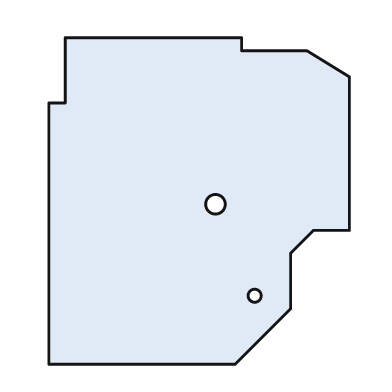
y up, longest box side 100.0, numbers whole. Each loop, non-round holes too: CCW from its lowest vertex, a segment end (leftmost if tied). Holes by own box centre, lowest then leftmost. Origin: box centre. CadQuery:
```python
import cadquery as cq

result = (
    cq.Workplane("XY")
    .moveTo(-46.0, -50.0)
    .lineTo(11.0, -50.0)
    .lineTo(28.0, -33.0)
    .lineTo(28.0, -16.0)
    .lineTo(35.0, -9.0)
    .lineTo(46.0, -9.0)
    .lineTo(46.0, 38.0)
    .lineTo(33.0, 46.0)
    .lineTo(13.0, 46.0)
    .lineTo(13.0, 50.0)
    .lineTo(-41.0, 50.0)
    .lineTo(-41.0, 30.0)
    .lineTo(-46.0, 30.0)
    .close()
    .moveTo(17.0, -29.0)
    .circle(2.0)
    .moveTo(5.0, -1.0)
    .circle(3.0)
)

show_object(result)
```